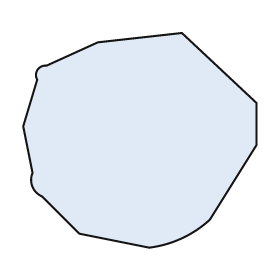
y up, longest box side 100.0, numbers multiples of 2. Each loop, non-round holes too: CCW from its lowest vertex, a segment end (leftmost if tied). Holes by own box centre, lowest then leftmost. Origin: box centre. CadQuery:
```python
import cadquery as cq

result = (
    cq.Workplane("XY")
    .moveTo(4.0, -46.0)
    .threePointArc((18.0, -42.0), (30.0, -34.0))
    .lineTo(50.0, -2.0)
    .lineTo(50.0, 16.0)
    .lineTo(18.0, 46.0)
    .lineTo(-18.0, 42.0)
    .lineTo(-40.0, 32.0)
    .threePointArc((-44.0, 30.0), (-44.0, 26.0))
    .lineTo(-50.0, 6.0)
    .lineTo(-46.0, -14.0)
    .threePointArc((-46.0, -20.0), (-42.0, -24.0))
    .lineTo(-26.0, -40.0)
    .close()
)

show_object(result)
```